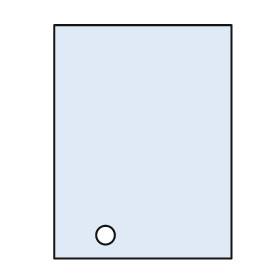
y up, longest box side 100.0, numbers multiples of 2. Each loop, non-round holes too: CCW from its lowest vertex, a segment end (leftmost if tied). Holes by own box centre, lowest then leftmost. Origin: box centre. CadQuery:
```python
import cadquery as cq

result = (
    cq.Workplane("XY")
    .moveTo(-38.0, -50.0)
    .lineTo(38.0, -50.0)
    .lineTo(38.0, 50.0)
    .lineTo(-38.0, 50.0)
    .close()
    .moveTo(-16.0, -40.0)
    .circle(4.0)
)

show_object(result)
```